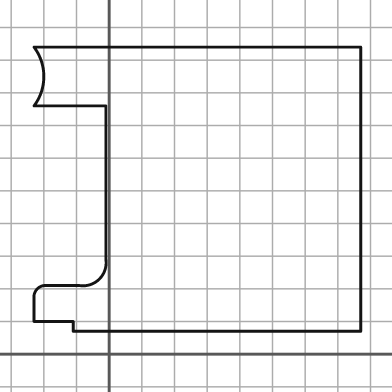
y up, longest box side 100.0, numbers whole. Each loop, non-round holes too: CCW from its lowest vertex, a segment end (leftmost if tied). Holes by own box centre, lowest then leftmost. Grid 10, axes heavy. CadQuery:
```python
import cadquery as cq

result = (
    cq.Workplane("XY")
    .moveTo(-11.0, 7.0)
    .lineTo(77.0, 7.0)
    .lineTo(77.0, 94.0)
    .lineTo(-23.0, 94.0)
    .threePointArc((-20.0, 85.0), (-23.0, 76.0))
    .lineTo(-1.0, 76.0)
    .lineTo(-1.0, 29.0)
    .threePointArc((-3.0, 23.0), (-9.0, 21.0))
    .lineTo(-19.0, 21.0)
    .threePointArc((-22.0, 20.0), (-23.0, 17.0))
    .lineTo(-23.0, 10.0)
    .lineTo(-11.0, 10.0)
    .close()
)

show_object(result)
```